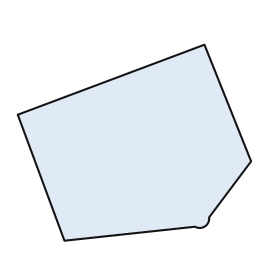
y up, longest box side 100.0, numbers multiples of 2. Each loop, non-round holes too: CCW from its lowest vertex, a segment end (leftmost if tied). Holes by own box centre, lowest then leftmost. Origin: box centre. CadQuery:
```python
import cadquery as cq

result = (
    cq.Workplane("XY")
    .moveTo(-30.0, -42.0)
    .lineTo(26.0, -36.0)
    .threePointArc((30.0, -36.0), (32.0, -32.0))
    .lineTo(50.0, -8.0)
    .lineTo(30.0, 42.0)
    .lineTo(-50.0, 12.0)
    .close()
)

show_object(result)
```